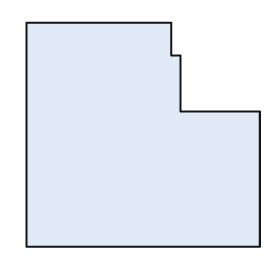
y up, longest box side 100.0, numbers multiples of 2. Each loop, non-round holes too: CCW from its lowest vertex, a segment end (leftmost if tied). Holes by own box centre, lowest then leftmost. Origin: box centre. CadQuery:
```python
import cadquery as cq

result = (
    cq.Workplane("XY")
    .moveTo(-50.0, -48.0)
    .lineTo(50.0, -48.0)
    .lineTo(50.0, 10.0)
    .lineTo(16.0, 10.0)
    .lineTo(16.0, 34.0)
    .lineTo(12.0, 34.0)
    .lineTo(12.0, 48.0)
    .lineTo(-50.0, 48.0)
    .close()
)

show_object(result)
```